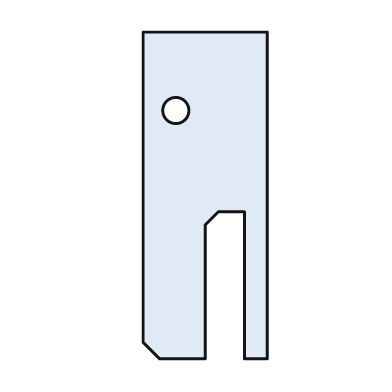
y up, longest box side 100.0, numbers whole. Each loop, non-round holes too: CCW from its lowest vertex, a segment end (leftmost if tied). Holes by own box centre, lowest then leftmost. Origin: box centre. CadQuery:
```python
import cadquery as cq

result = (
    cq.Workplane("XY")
    .moveTo(-14.0, -50.0)
    .lineTo(0.0, -50.0)
    .lineTo(0.0, -9.0)
    .lineTo(4.0, -5.0)
    .lineTo(12.0, -5.0)
    .lineTo(12.0, -50.0)
    .lineTo(19.0, -50.0)
    .lineTo(19.0, 50.0)
    .lineTo(-19.0, 50.0)
    .lineTo(-19.0, -45.0)
    .close()
    .moveTo(-9.0, 26.0)
    .circle(4.0)
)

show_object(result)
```